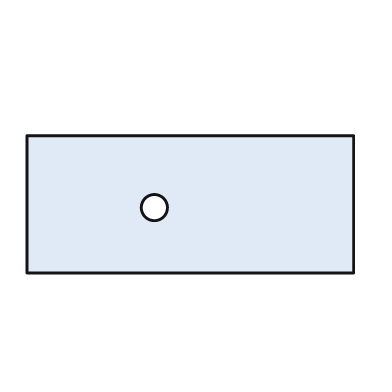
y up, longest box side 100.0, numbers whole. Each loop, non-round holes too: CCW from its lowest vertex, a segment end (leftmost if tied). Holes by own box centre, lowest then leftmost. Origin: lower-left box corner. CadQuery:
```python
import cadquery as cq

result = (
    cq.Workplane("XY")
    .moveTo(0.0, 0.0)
    .lineTo(100.0, 0.0)
    .lineTo(100.0, 42.0)
    .lineTo(0.0, 42.0)
    .close()
    .moveTo(39.0, 20.0)
    .circle(4.0)
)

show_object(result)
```